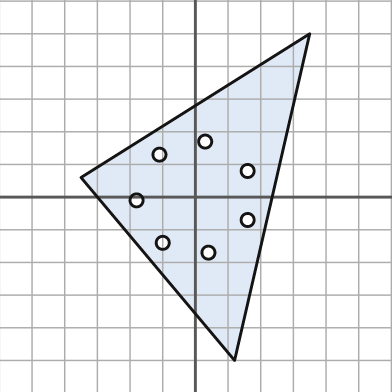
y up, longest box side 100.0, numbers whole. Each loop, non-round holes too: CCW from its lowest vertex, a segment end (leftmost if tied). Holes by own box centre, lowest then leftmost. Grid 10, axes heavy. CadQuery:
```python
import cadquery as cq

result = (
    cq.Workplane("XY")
    .moveTo(12.0, -50.0)
    .lineTo(35.0, 50.0)
    .lineTo(-35.0, 6.0)
    .close()
    .moveTo(4.0, -17.0)
    .circle(2.0)
    .moveTo(-10.0, -14.0)
    .circle(2.0)
    .moveTo(16.0, -7.0)
    .circle(2.0)
    .moveTo(-18.0, -1.0)
    .circle(2.0)
    .moveTo(16.0, 8.0)
    .circle(2.0)
    .moveTo(-11.0, 13.0)
    .circle(2.0)
    .moveTo(3.0, 17.0)
    .circle(2.0)
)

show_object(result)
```